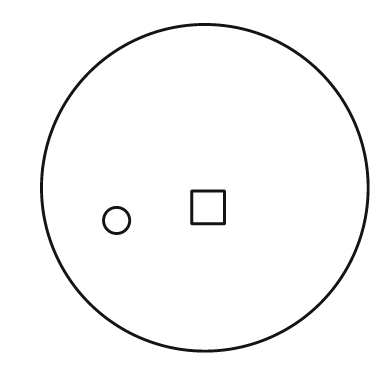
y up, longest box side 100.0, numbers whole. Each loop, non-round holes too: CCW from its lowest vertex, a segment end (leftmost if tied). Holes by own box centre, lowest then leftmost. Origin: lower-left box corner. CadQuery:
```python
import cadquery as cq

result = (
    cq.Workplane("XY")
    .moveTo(50.0, 50.0)
    .circle(50.0)
    .moveTo(23.0, 40.0)
    .circle(4.0)
    .moveTo(46.0, 39.0)
    .lineTo(56.0, 39.0)
    .lineTo(56.0, 49.0)
    .lineTo(46.0, 49.0)
    .close()
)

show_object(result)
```